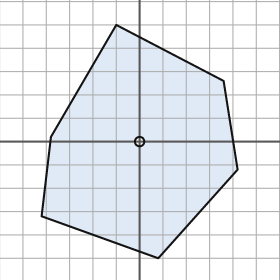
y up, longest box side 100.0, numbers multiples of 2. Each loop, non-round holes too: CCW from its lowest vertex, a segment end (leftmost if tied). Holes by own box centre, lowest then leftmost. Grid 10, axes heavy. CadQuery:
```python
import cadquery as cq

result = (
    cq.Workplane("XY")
    .moveTo(8.0, -50.0)
    .lineTo(42.0, -12.0)
    .lineTo(36.0, 26.0)
    .lineTo(-10.0, 50.0)
    .lineTo(-38.0, 2.0)
    .lineTo(-42.0, -32.0)
    .close()
    .moveTo(0.0, 0.0)
    .circle(2.0)
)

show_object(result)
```